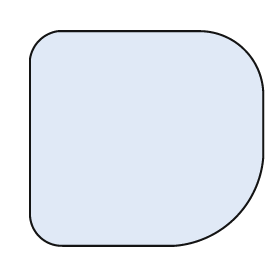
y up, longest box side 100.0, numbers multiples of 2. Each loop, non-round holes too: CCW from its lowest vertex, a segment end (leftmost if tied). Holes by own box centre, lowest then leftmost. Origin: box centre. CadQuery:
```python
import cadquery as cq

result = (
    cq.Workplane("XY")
    .moveTo(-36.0, -46.0)
    .lineTo(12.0, -46.0)
    .threePointArc((38.0, -34.0), (50.0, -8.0))
    .lineTo(50.0, 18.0)
    .threePointArc((42.0, 38.0), (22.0, 46.0))
    .lineTo(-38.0, 46.0)
    .threePointArc((-46.0, 42.0), (-50.0, 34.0))
    .lineTo(-50.0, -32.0)
    .threePointArc((-46.0, -42.0), (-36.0, -46.0))
    .close()
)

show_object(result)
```